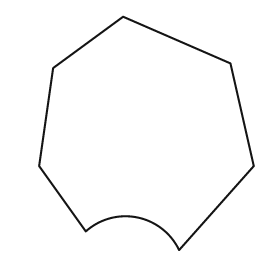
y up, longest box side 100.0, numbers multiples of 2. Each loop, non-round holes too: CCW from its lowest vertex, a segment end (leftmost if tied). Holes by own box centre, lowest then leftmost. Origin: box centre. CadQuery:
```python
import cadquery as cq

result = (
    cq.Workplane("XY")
    .moveTo(14.0, -50.0)
    .lineTo(46.0, -14.0)
    .lineTo(36.0, 30.0)
    .lineTo(-10.0, 50.0)
    .lineTo(-40.0, 28.0)
    .lineTo(-46.0, -14.0)
    .lineTo(-26.0, -42.0)
    .threePointArc((-4.0, -36.0), (14.0, -50.0))
    .close()
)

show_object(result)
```